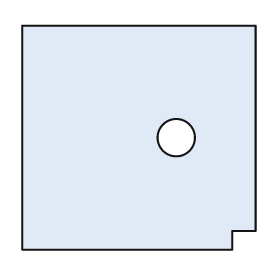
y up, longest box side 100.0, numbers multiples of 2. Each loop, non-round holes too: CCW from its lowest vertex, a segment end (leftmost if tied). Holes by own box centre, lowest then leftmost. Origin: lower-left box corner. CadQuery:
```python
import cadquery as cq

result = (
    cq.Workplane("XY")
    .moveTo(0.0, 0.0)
    .lineTo(90.0, 0.0)
    .lineTo(90.0, 8.0)
    .lineTo(100.0, 8.0)
    .lineTo(100.0, 96.0)
    .lineTo(0.0, 96.0)
    .close()
    .moveTo(66.0, 48.0)
    .circle(8.0)
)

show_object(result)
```